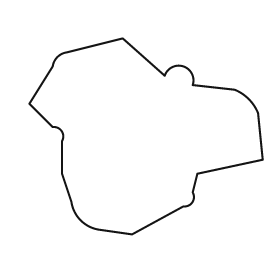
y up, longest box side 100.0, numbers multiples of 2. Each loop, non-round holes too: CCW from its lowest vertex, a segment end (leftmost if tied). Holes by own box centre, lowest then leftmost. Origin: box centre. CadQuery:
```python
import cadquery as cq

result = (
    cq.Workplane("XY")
    .moveTo(-6.0, -42.0)
    .lineTo(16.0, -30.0)
    .threePointArc((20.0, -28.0), (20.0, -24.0))
    .lineTo(22.0, -16.0)
    .lineTo(50.0, -10.0)
    .lineTo(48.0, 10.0)
    .threePointArc((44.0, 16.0), (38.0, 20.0))
    .lineTo(20.0, 22.0)
    .threePointArc((16.0, 30.0), (8.0, 26.0))
    .lineTo(-10.0, 42.0)
    .lineTo(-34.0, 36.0)
    .threePointArc((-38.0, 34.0), (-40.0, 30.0))
    .lineTo(-50.0, 14.0)
    .lineTo(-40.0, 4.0)
    .threePointArc((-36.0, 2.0), (-36.0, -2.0))
    .lineTo(-36.0, -16.0)
    .lineTo(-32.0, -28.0)
    .threePointArc((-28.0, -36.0), (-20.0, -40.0))
    .close()
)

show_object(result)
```